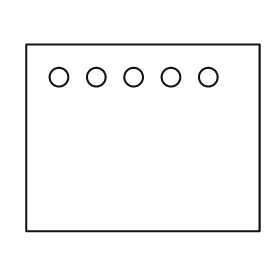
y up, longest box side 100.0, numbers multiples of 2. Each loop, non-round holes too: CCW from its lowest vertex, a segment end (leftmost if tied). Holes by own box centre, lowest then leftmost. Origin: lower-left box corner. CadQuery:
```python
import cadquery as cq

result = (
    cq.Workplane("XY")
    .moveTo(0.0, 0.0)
    .lineTo(100.0, 0.0)
    .lineTo(100.0, 80.0)
    .lineTo(0.0, 80.0)
    .close()
    .moveTo(14.0, 66.0)
    .circle(4.0)
    .moveTo(30.0, 66.0)
    .circle(4.0)
    .moveTo(46.0, 66.0)
    .circle(4.0)
    .moveTo(62.0, 66.0)
    .circle(4.0)
    .moveTo(78.0, 66.0)
    .circle(4.0)
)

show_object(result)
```